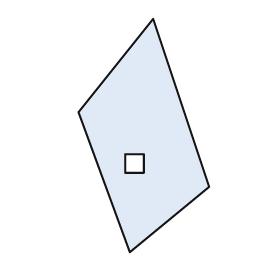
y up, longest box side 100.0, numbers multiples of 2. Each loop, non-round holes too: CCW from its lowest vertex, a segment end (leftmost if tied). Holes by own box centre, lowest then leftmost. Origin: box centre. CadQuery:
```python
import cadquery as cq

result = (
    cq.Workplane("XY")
    .moveTo(-6.0, -50.0)
    .lineTo(28.0, -22.0)
    .lineTo(4.0, 50.0)
    .lineTo(-28.0, 10.0)
    .close()
    .moveTo(-8.0, -16.0)
    .lineTo(0.0, -16.0)
    .lineTo(0.0, -8.0)
    .lineTo(-8.0, -8.0)
    .close()
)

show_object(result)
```